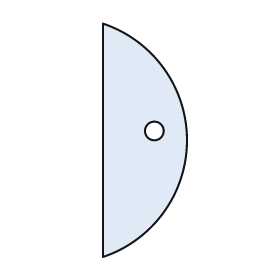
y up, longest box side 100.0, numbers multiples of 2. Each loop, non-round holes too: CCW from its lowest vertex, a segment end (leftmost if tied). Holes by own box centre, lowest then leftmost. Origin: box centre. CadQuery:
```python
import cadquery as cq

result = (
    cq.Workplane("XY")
    .moveTo(-18.0, -50.0)
    .threePointArc((18.0, 0.0), (-18.0, 50.0))
    .close()
    .moveTo(4.0, 4.0)
    .circle(4.0)
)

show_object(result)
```